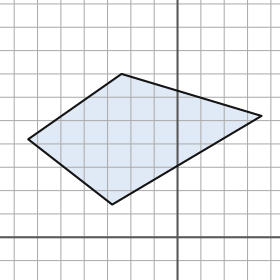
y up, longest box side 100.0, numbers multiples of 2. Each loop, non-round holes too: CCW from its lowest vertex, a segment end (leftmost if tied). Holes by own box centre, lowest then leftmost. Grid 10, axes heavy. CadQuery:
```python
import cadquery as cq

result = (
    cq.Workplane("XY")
    .moveTo(-28.0, 14.0)
    .lineTo(36.0, 52.0)
    .lineTo(-24.0, 70.0)
    .lineTo(-64.0, 42.0)
    .close()
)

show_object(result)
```